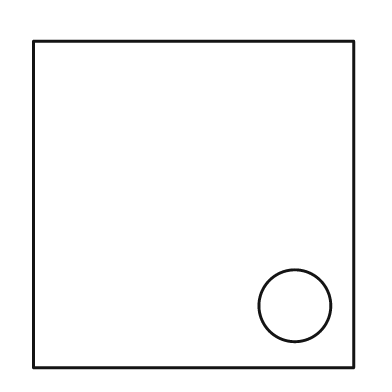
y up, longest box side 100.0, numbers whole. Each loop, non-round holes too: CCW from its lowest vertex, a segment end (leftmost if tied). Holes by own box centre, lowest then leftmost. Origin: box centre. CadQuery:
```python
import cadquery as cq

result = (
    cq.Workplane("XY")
    .moveTo(-49.0, -50.0)
    .lineTo(49.0, -50.0)
    .lineTo(49.0, 50.0)
    .lineTo(-49.0, 50.0)
    .close()
    .moveTo(31.0, -31.0)
    .circle(11.0)
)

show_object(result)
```